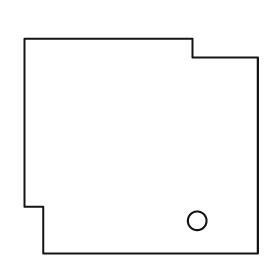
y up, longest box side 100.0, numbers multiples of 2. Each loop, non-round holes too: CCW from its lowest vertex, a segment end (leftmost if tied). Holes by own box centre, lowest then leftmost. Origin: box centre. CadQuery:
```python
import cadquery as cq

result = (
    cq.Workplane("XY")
    .moveTo(-42.0, -46.0)
    .lineTo(50.0, -46.0)
    .lineTo(50.0, 38.0)
    .lineTo(22.0, 38.0)
    .lineTo(22.0, 46.0)
    .lineTo(-50.0, 46.0)
    .lineTo(-50.0, -26.0)
    .lineTo(-42.0, -26.0)
    .close()
    .moveTo(24.0, -32.0)
    .circle(4.0)
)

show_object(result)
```